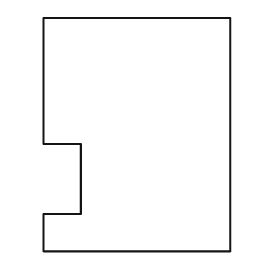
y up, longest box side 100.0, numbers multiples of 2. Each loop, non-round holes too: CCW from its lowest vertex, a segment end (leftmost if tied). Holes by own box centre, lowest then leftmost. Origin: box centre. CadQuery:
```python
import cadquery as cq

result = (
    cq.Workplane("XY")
    .moveTo(-40.0, -50.0)
    .lineTo(40.0, -50.0)
    .lineTo(40.0, 50.0)
    .lineTo(-40.0, 50.0)
    .lineTo(-40.0, -4.0)
    .lineTo(-24.0, -4.0)
    .lineTo(-24.0, -34.0)
    .lineTo(-40.0, -34.0)
    .close()
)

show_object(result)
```